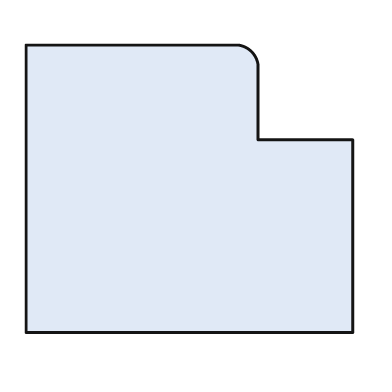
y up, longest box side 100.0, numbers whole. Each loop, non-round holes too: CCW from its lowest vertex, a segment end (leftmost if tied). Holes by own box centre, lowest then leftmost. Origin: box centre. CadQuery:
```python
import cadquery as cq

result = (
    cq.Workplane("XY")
    .moveTo(-50.0, -44.0)
    .lineTo(50.0, -44.0)
    .lineTo(50.0, 15.0)
    .lineTo(21.0, 15.0)
    .lineTo(21.0, 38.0)
    .threePointArc((19.0, 42.0), (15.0, 44.0))
    .lineTo(-50.0, 44.0)
    .close()
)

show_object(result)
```